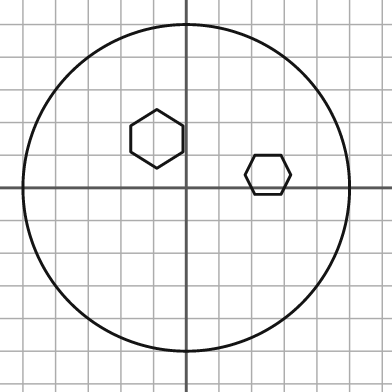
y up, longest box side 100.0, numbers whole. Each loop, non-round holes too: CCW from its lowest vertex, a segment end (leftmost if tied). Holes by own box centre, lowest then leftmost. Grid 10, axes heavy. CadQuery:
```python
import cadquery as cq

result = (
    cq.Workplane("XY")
    .moveTo(0.0, 0.0)
    .circle(50.0)
    .moveTo(21.0, -2.0)
    .lineTo(29.0, -2.0)
    .lineTo(32.0, 4.0)
    .lineTo(29.0, 10.0)
    .lineTo(21.0, 10.0)
    .lineTo(18.0, 4.0)
    .close()
    .moveTo(-9.0, 6.0)
    .lineTo(-1.0, 11.0)
    .lineTo(-1.0, 19.0)
    .lineTo(-9.0, 24.0)
    .lineTo(-17.0, 19.0)
    .lineTo(-17.0, 11.0)
    .close()
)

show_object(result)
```